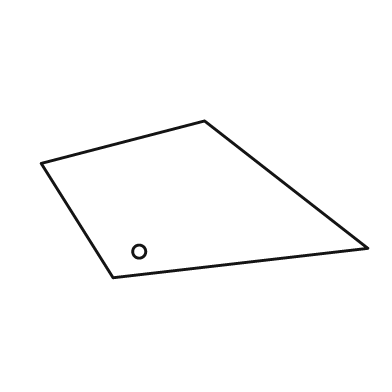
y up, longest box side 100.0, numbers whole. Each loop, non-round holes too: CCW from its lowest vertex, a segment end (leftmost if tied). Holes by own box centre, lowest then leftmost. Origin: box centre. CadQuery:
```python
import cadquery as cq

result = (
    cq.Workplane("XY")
    .moveTo(-28.0, -24.0)
    .lineTo(50.0, -15.0)
    .lineTo(0.0, 24.0)
    .lineTo(-50.0, 11.0)
    .close()
    .moveTo(-20.0, -16.0)
    .circle(2.0)
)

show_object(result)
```